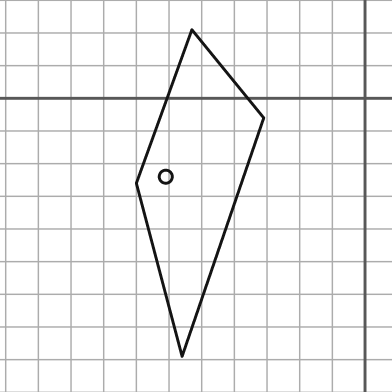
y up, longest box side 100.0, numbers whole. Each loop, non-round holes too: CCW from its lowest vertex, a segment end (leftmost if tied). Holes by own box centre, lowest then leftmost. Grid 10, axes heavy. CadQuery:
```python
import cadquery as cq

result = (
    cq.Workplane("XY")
    .moveTo(-56.0, -79.0)
    .lineTo(-31.0, -6.0)
    .lineTo(-53.0, 21.0)
    .lineTo(-70.0, -26.0)
    .close()
    .moveTo(-61.0, -24.0)
    .circle(2.0)
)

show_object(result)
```